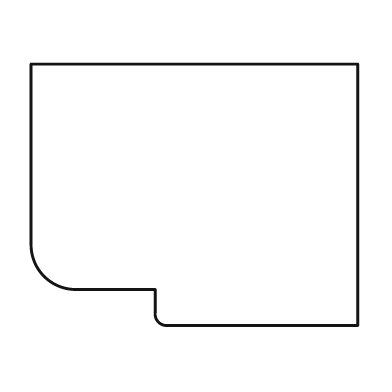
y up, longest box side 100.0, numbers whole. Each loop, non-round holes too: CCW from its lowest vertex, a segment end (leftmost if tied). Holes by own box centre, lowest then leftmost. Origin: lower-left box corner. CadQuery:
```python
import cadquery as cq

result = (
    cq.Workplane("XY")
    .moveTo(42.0, 0.0)
    .lineTo(100.0, 0.0)
    .lineTo(100.0, 80.0)
    .lineTo(0.0, 80.0)
    .lineTo(0.0, 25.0)
    .threePointArc((4.0, 15.0), (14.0, 11.0))
    .lineTo(38.0, 11.0)
    .lineTo(38.0, 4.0)
    .threePointArc((39.0, 1.0), (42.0, 0.0))
    .close()
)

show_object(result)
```